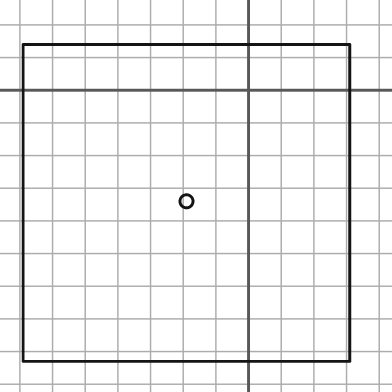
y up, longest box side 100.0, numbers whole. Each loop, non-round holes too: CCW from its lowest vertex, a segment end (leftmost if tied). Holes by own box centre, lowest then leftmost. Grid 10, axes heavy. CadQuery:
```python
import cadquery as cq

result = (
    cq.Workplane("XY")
    .moveTo(-69.0, -83.0)
    .lineTo(31.0, -83.0)
    .lineTo(31.0, 14.0)
    .lineTo(-69.0, 14.0)
    .close()
    .moveTo(-19.0, -34.0)
    .circle(2.0)
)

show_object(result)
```